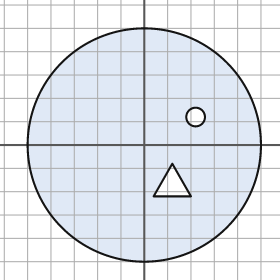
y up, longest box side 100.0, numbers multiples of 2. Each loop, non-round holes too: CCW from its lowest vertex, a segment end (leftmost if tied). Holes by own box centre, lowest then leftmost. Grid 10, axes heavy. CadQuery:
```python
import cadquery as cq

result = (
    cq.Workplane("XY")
    .moveTo(0.0, 0.0)
    .circle(50.0)
    .moveTo(4.0, -22.0)
    .lineTo(20.0, -22.0)
    .lineTo(12.0, -8.0)
    .close()
    .moveTo(22.0, 12.0)
    .circle(4.0)
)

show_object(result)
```